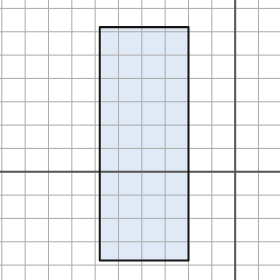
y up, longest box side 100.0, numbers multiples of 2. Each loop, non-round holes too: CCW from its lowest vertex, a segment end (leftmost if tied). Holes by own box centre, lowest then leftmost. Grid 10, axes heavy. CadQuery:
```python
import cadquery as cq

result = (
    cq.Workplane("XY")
    .moveTo(-58.0, -38.0)
    .lineTo(-20.0, -38.0)
    .lineTo(-20.0, 62.0)
    .lineTo(-58.0, 62.0)
    .close()
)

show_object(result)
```